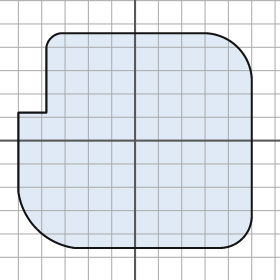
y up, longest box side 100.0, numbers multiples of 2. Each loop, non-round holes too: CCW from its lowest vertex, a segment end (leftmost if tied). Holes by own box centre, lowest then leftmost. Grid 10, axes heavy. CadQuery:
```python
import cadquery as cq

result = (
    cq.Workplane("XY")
    .moveTo(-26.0, -46.0)
    .lineTo(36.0, -46.0)
    .threePointArc((46.0, -42.0), (50.0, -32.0))
    .lineTo(50.0, 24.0)
    .threePointArc((44.0, 40.0), (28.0, 46.0))
    .lineTo(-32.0, 46.0)
    .threePointArc((-36.0, 44.0), (-38.0, 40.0))
    .lineTo(-38.0, 12.0)
    .lineTo(-50.0, 12.0)
    .lineTo(-50.0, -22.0)
    .threePointArc((-42.0, -38.0), (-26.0, -46.0))
    .close()
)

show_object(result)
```